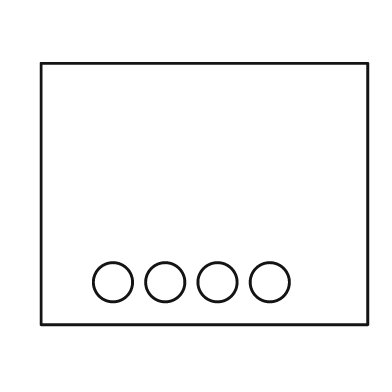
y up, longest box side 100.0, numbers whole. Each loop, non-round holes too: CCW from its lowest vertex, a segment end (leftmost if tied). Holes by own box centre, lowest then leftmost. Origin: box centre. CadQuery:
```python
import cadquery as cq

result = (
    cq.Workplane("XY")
    .moveTo(-50.0, -40.0)
    .lineTo(50.0, -40.0)
    .lineTo(50.0, 40.0)
    .lineTo(-50.0, 40.0)
    .close()
    .moveTo(-28.0, -27.0)
    .circle(6.0)
    .moveTo(-12.0, -27.0)
    .circle(6.0)
    .moveTo(4.0, -27.0)
    .circle(6.0)
    .moveTo(20.0, -27.0)
    .circle(6.0)
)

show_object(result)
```